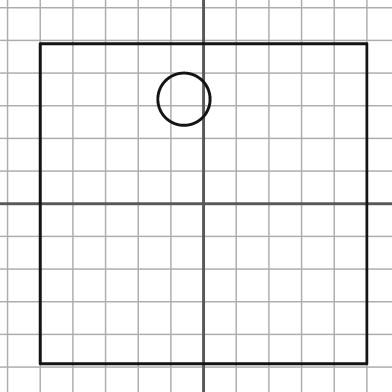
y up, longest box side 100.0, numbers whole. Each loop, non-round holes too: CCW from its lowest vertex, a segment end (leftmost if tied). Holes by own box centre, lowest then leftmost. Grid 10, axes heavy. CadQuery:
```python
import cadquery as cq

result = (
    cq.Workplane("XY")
    .moveTo(-50.0, -49.0)
    .lineTo(50.0, -49.0)
    .lineTo(50.0, 49.0)
    .lineTo(-50.0, 49.0)
    .close()
    .moveTo(-6.0, 32.0)
    .circle(8.0)
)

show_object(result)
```